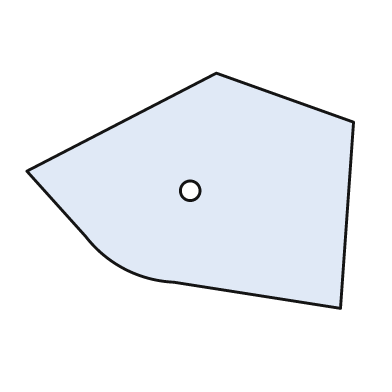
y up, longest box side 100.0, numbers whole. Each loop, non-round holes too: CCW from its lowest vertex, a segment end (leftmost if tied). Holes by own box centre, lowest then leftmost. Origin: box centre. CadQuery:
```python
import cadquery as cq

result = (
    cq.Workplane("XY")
    .moveTo(46.0, -36.0)
    .lineTo(50.0, 21.0)
    .lineTo(8.0, 36.0)
    .lineTo(-50.0, 6.0)
    .lineTo(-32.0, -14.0)
    .threePointArc((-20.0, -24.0), (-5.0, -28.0))
    .close()
    .moveTo(0.0, 0.0)
    .circle(3.0)
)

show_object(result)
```